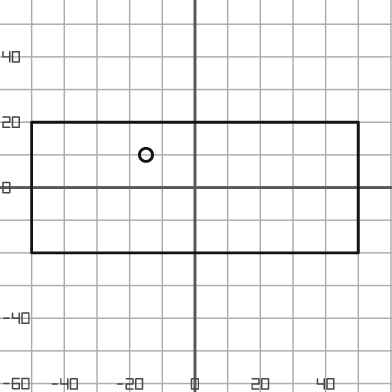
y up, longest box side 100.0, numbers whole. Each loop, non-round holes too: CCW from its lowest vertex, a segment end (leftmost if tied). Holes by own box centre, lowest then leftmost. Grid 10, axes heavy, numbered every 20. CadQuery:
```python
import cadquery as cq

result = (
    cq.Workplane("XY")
    .moveTo(-50.0, -20.0)
    .lineTo(50.0, -20.0)
    .lineTo(50.0, 20.0)
    .lineTo(-50.0, 20.0)
    .close()
    .moveTo(-15.0, 10.0)
    .circle(2.0)
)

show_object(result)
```